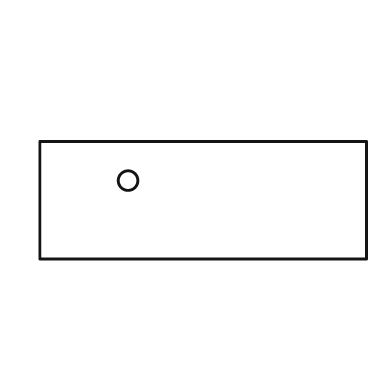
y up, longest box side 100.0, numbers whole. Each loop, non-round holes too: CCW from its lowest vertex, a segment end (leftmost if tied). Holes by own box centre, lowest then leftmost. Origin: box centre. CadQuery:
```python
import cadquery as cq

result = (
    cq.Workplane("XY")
    .moveTo(-50.0, -18.0)
    .lineTo(50.0, -18.0)
    .lineTo(50.0, 18.0)
    .lineTo(-50.0, 18.0)
    .close()
    .moveTo(-23.0, 6.0)
    .circle(3.0)
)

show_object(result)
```